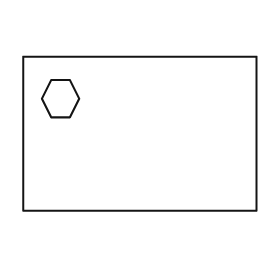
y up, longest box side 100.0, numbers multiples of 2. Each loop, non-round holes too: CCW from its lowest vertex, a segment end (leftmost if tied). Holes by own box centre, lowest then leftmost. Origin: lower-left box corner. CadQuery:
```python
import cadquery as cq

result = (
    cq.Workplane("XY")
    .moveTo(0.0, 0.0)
    .lineTo(100.0, 0.0)
    .lineTo(100.0, 66.0)
    .lineTo(0.0, 66.0)
    .close()
    .moveTo(12.0, 40.0)
    .lineTo(20.0, 40.0)
    .lineTo(24.0, 48.0)
    .lineTo(20.0, 56.0)
    .lineTo(12.0, 56.0)
    .lineTo(8.0, 48.0)
    .close()
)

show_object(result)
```